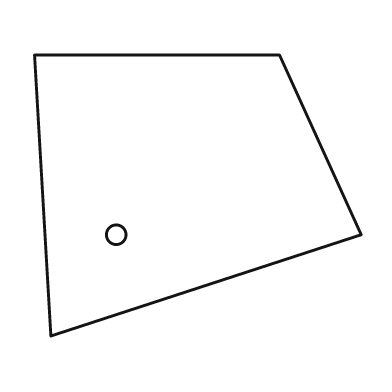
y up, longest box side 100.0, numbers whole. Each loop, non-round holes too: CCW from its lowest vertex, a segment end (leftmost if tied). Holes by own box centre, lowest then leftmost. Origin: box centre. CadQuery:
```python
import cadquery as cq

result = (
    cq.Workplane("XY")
    .moveTo(-45.0, -43.0)
    .lineTo(50.0, -12.0)
    .lineTo(25.0, 43.0)
    .lineTo(-50.0, 43.0)
    .close()
    .moveTo(-25.0, -12.0)
    .circle(3.0)
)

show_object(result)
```